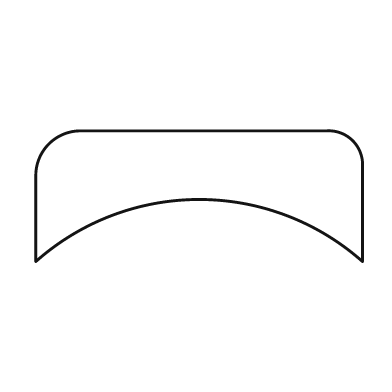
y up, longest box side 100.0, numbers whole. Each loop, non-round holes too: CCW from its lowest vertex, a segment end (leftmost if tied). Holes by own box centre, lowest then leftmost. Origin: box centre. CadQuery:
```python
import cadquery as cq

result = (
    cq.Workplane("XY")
    .moveTo(-50.0, -20.0)
    .threePointArc((0.0, -1.0), (50.0, -20.0))
    .lineTo(50.0, 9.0)
    .threePointArc((47.0, 17.0), (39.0, 20.0))
    .lineTo(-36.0, 20.0)
    .threePointArc((-46.0, 16.0), (-50.0, 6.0))
    .close()
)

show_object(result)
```